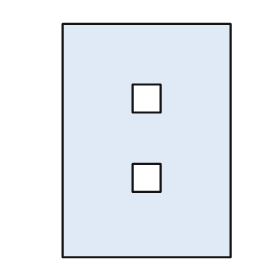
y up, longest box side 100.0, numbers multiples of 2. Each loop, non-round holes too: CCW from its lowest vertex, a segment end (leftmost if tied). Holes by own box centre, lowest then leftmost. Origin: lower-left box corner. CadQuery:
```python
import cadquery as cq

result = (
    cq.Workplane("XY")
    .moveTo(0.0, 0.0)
    .lineTo(72.0, 0.0)
    .lineTo(72.0, 100.0)
    .lineTo(0.0, 100.0)
    .close()
    .moveTo(30.0, 28.0)
    .lineTo(42.0, 28.0)
    .lineTo(42.0, 40.0)
    .lineTo(30.0, 40.0)
    .close()
    .moveTo(30.0, 62.0)
    .lineTo(42.0, 62.0)
    .lineTo(42.0, 74.0)
    .lineTo(30.0, 74.0)
    .close()
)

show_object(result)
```